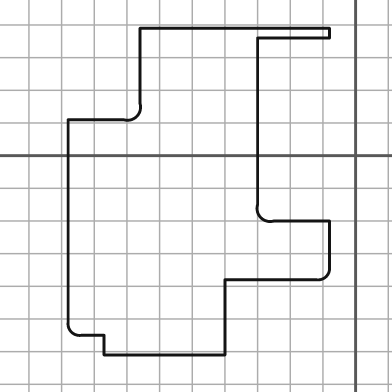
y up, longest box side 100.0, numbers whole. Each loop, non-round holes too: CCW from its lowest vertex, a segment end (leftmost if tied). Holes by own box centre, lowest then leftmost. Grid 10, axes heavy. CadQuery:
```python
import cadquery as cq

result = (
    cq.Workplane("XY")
    .moveTo(-77.0, -61.0)
    .lineTo(-40.0, -61.0)
    .lineTo(-40.0, -38.0)
    .lineTo(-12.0, -38.0)
    .threePointArc((-9.0, -37.0), (-8.0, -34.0))
    .lineTo(-8.0, -20.0)
    .lineTo(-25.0, -20.0)
    .threePointArc((-29.0, -19.0), (-30.0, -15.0))
    .lineTo(-30.0, 36.0)
    .lineTo(-8.0, 36.0)
    .lineTo(-8.0, 39.0)
    .lineTo(-66.0, 39.0)
    .lineTo(-66.0, 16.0)
    .threePointArc((-67.0, 12.0), (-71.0, 11.0))
    .lineTo(-88.0, 11.0)
    .lineTo(-88.0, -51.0)
    .threePointArc((-87.0, -54.0), (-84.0, -55.0))
    .lineTo(-77.0, -55.0)
    .close()
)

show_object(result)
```